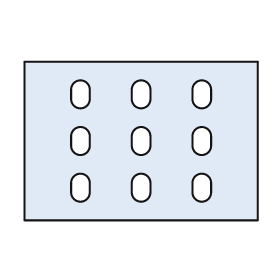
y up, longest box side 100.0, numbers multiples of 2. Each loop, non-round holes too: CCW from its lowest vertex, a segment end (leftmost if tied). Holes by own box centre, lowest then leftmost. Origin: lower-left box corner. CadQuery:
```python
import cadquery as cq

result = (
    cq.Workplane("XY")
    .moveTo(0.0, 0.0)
    .lineTo(100.0, 0.0)
    .lineTo(100.0, 68.0)
    .lineTo(0.0, 68.0)
    .close()
    .moveTo(20.0, 12.0)
    .threePointArc((24.0, 8.0), (28.0, 12.0))
    .lineTo(28.0, 16.0)
    .threePointArc((24.0, 20.0), (20.0, 16.0))
    .close()
    .moveTo(46.0, 12.0)
    .threePointArc((50.0, 8.0), (54.0, 12.0))
    .lineTo(54.0, 16.0)
    .threePointArc((50.0, 20.0), (46.0, 16.0))
    .close()
    .moveTo(72.0, 12.0)
    .threePointArc((76.0, 8.0), (80.0, 12.0))
    .lineTo(80.0, 16.0)
    .threePointArc((76.0, 20.0), (72.0, 16.0))
    .close()
    .moveTo(20.0, 32.0)
    .threePointArc((24.0, 28.0), (28.0, 32.0))
    .lineTo(28.0, 36.0)
    .threePointArc((24.0, 40.0), (20.0, 36.0))
    .close()
    .moveTo(46.0, 32.0)
    .threePointArc((50.0, 28.0), (54.0, 32.0))
    .lineTo(54.0, 36.0)
    .threePointArc((50.0, 40.0), (46.0, 36.0))
    .close()
    .moveTo(72.0, 32.0)
    .threePointArc((76.0, 28.0), (80.0, 32.0))
    .lineTo(80.0, 36.0)
    .threePointArc((76.0, 40.0), (72.0, 36.0))
    .close()
    .moveTo(20.0, 52.0)
    .threePointArc((24.0, 48.0), (28.0, 52.0))
    .lineTo(28.0, 56.0)
    .threePointArc((24.0, 60.0), (20.0, 56.0))
    .close()
    .moveTo(46.0, 52.0)
    .threePointArc((50.0, 48.0), (54.0, 52.0))
    .lineTo(54.0, 56.0)
    .threePointArc((50.0, 60.0), (46.0, 56.0))
    .close()
    .moveTo(72.0, 52.0)
    .threePointArc((76.0, 48.0), (80.0, 52.0))
    .lineTo(80.0, 56.0)
    .threePointArc((76.0, 60.0), (72.0, 56.0))
    .close()
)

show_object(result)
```